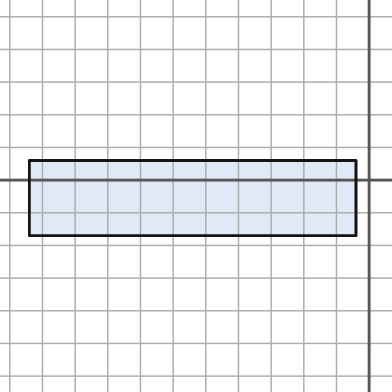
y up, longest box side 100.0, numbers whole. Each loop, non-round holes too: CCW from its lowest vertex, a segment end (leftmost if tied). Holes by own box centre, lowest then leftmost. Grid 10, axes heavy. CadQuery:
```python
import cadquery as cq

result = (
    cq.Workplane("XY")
    .moveTo(-104.0, -17.0)
    .lineTo(-4.0, -17.0)
    .lineTo(-4.0, 6.0)
    .lineTo(-104.0, 6.0)
    .close()
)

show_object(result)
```